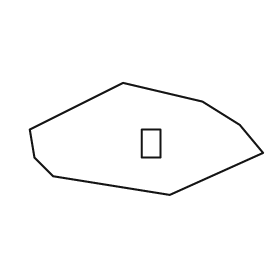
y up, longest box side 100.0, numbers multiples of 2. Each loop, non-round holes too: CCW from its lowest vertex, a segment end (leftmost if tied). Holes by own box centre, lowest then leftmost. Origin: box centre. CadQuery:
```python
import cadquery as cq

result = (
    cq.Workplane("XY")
    .moveTo(10.0, -24.0)
    .lineTo(50.0, -6.0)
    .lineTo(40.0, 6.0)
    .lineTo(24.0, 16.0)
    .lineTo(-10.0, 24.0)
    .lineTo(-50.0, 4.0)
    .lineTo(-48.0, -8.0)
    .lineTo(-40.0, -16.0)
    .close()
    .moveTo(-2.0, -8.0)
    .lineTo(6.0, -8.0)
    .lineTo(6.0, 4.0)
    .lineTo(-2.0, 4.0)
    .close()
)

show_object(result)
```